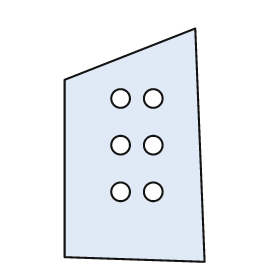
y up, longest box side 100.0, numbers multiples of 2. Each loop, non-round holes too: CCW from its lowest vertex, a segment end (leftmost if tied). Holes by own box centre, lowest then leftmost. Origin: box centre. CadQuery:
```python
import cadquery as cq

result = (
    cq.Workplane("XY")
    .moveTo(30.0, -50.0)
    .lineTo(26.0, 50.0)
    .lineTo(-30.0, 28.0)
    .lineTo(-30.0, -48.0)
    .close()
    .moveTo(-6.0, -20.0)
    .circle(4.0)
    .moveTo(8.0, -20.0)
    .circle(4.0)
    .moveTo(-6.0, 0.0)
    .circle(4.0)
    .moveTo(8.0, 0.0)
    .circle(4.0)
    .moveTo(-6.0, 20.0)
    .circle(4.0)
    .moveTo(8.0, 20.0)
    .circle(4.0)
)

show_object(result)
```